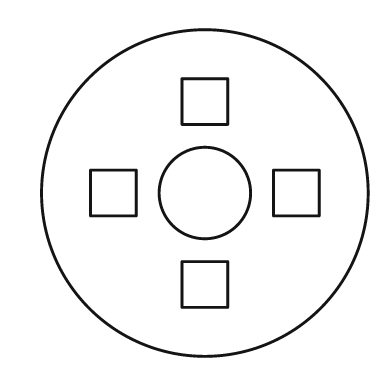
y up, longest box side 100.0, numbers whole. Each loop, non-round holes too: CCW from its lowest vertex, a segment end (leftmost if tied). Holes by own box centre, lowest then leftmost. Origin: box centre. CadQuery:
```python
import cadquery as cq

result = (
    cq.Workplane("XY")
    .moveTo(0.0, 0.0)
    .circle(50.0)
    .moveTo(-7.0, -35.0)
    .lineTo(7.0, -35.0)
    .lineTo(7.0, -21.0)
    .lineTo(-7.0, -21.0)
    .close()
    .moveTo(-35.0, -7.0)
    .lineTo(-21.0, -7.0)
    .lineTo(-21.0, 7.0)
    .lineTo(-35.0, 7.0)
    .close()
    .moveTo(0.0, 0.0)
    .circle(14.0)
    .moveTo(21.0, -7.0)
    .lineTo(35.0, -7.0)
    .lineTo(35.0, 7.0)
    .lineTo(21.0, 7.0)
    .close()
    .moveTo(-7.0, 21.0)
    .lineTo(7.0, 21.0)
    .lineTo(7.0, 35.0)
    .lineTo(-7.0, 35.0)
    .close()
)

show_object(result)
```